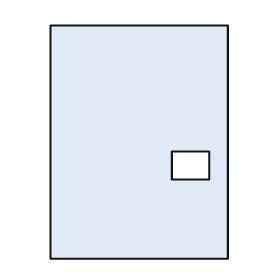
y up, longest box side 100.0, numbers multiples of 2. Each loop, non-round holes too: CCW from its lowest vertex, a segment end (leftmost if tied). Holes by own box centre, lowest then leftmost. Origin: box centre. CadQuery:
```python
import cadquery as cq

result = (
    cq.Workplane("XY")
    .moveTo(-38.0, -50.0)
    .lineTo(38.0, -50.0)
    .lineTo(38.0, 50.0)
    .lineTo(-38.0, 50.0)
    .close()
    .moveTo(14.0, -16.0)
    .lineTo(30.0, -16.0)
    .lineTo(30.0, -4.0)
    .lineTo(14.0, -4.0)
    .close()
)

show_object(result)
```